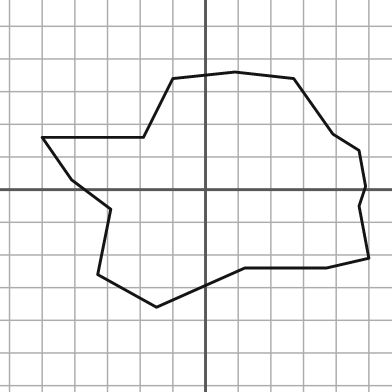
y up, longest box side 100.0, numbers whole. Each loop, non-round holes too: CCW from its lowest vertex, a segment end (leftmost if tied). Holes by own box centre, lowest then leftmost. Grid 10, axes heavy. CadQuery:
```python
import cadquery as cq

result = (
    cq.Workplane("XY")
    .moveTo(-15.0, -36.0)
    .lineTo(12.0, -24.0)
    .lineTo(37.0, -24.0)
    .lineTo(50.0, -21.0)
    .lineTo(47.0, -5.0)
    .lineTo(49.0, 1.0)
    .lineTo(47.0, 12.0)
    .lineTo(39.0, 17.0)
    .lineTo(27.0, 34.0)
    .lineTo(9.0, 36.0)
    .lineTo(-10.0, 34.0)
    .lineTo(-19.0, 16.0)
    .lineTo(-50.0, 16.0)
    .lineTo(-41.0, 3.0)
    .lineTo(-29.0, -6.0)
    .lineTo(-33.0, -26.0)
    .close()
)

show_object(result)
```